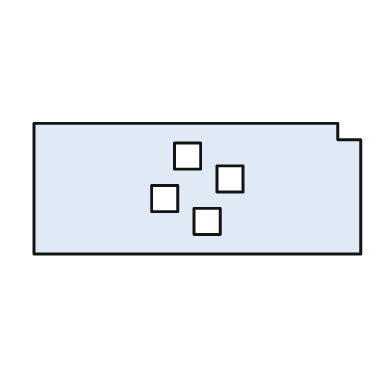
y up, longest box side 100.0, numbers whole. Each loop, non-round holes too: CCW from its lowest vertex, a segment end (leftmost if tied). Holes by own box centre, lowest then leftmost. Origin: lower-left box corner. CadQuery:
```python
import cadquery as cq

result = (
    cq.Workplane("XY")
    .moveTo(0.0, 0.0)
    .lineTo(100.0, 0.0)
    .lineTo(100.0, 35.0)
    .lineTo(93.0, 35.0)
    .lineTo(93.0, 40.0)
    .lineTo(0.0, 40.0)
    .close()
    .moveTo(49.0, 6.0)
    .lineTo(57.0, 6.0)
    .lineTo(57.0, 14.0)
    .lineTo(49.0, 14.0)
    .close()
    .moveTo(36.0, 13.0)
    .lineTo(44.0, 13.0)
    .lineTo(44.0, 21.0)
    .lineTo(36.0, 21.0)
    .close()
    .moveTo(56.0, 19.0)
    .lineTo(64.0, 19.0)
    .lineTo(64.0, 27.0)
    .lineTo(56.0, 27.0)
    .close()
    .moveTo(43.0, 26.0)
    .lineTo(51.0, 26.0)
    .lineTo(51.0, 34.0)
    .lineTo(43.0, 34.0)
    .close()
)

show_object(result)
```